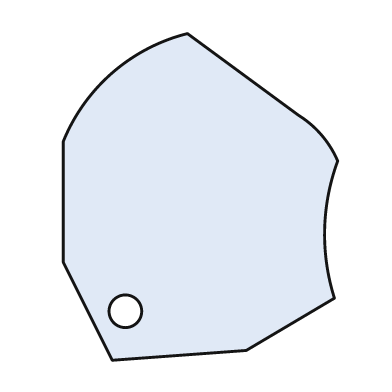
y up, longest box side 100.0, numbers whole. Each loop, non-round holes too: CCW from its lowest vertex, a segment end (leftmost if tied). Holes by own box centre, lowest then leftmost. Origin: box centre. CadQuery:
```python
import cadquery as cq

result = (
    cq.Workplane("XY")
    .moveTo(-27.0, -50.0)
    .lineTo(14.0, -47.0)
    .lineTo(41.0, -31.0)
    .threePointArc((38.0, -10.0), (42.0, 11.0))
    .threePointArc((37.0, 19.0), (30.0, 25.0))
    .lineTo(-4.0, 50.0)
    .threePointArc((-27.0, 38.0), (-42.0, 17.0))
    .lineTo(-42.0, -20.0)
    .close()
    .moveTo(-23.0, -35.0)
    .circle(5.0)
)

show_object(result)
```